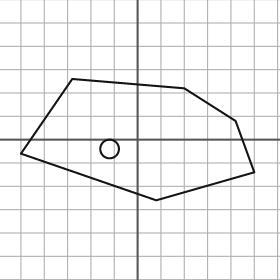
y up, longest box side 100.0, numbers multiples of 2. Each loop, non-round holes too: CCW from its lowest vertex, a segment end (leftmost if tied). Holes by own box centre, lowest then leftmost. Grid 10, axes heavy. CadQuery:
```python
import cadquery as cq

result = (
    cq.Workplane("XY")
    .moveTo(8.0, -26.0)
    .lineTo(50.0, -14.0)
    .lineTo(42.0, 8.0)
    .lineTo(20.0, 22.0)
    .lineTo(-28.0, 26.0)
    .lineTo(-50.0, -6.0)
    .close()
    .moveTo(-12.0, -4.0)
    .circle(4.0)
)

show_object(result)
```